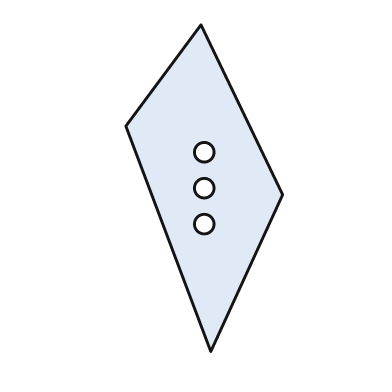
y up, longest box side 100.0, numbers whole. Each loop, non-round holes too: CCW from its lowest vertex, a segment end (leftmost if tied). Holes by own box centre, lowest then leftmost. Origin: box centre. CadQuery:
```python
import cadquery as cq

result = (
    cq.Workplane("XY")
    .moveTo(2.0, -50.0)
    .lineTo(24.0, -2.0)
    .lineTo(-1.0, 50.0)
    .lineTo(-24.0, 19.0)
    .close()
    .moveTo(0.0, -11.0)
    .circle(3.0)
    .moveTo(0.0, 0.0)
    .circle(3.0)
    .moveTo(0.0, 11.0)
    .circle(3.0)
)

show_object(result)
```